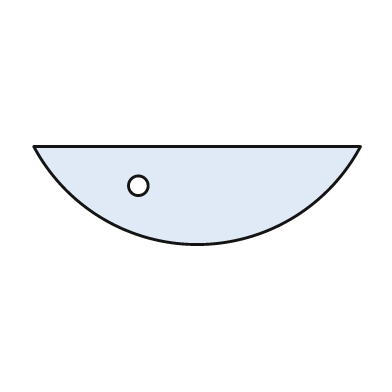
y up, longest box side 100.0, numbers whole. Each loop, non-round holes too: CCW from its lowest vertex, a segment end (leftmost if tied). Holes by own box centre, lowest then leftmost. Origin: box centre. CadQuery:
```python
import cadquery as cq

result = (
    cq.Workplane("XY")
    .moveTo(-50.0, 15.0)
    .threePointArc((0.0, -15.0), (50.0, 15.0))
    .close()
    .moveTo(-18.0, 3.0)
    .circle(3.0)
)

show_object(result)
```